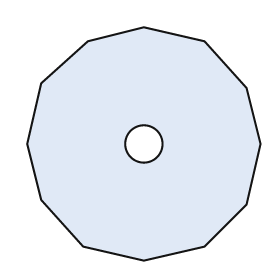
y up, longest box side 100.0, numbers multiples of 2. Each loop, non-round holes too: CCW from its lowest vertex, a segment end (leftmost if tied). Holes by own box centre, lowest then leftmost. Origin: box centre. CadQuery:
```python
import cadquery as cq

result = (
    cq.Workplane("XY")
    .moveTo(0.0, -50.0)
    .lineTo(26.0, -44.0)
    .lineTo(44.0, -26.0)
    .lineTo(50.0, 0.0)
    .lineTo(44.0, 24.0)
    .lineTo(26.0, 44.0)
    .lineTo(0.0, 50.0)
    .lineTo(-24.0, 44.0)
    .lineTo(-44.0, 26.0)
    .lineTo(-50.0, 0.0)
    .lineTo(-44.0, -24.0)
    .lineTo(-26.0, -44.0)
    .close()
    .moveTo(0.0, 0.0)
    .circle(8.0)
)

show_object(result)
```